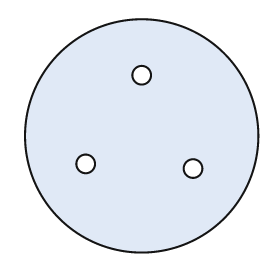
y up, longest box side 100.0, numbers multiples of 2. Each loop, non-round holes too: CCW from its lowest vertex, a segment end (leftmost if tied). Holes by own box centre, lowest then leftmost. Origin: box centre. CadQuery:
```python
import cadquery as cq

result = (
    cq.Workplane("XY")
    .moveTo(0.0, 0.0)
    .circle(50.0)
    .moveTo(22.0, -14.0)
    .circle(4.0)
    .moveTo(-24.0, -12.0)
    .circle(4.0)
    .moveTo(0.0, 26.0)
    .circle(4.0)
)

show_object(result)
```